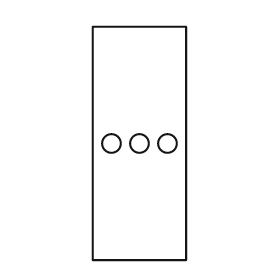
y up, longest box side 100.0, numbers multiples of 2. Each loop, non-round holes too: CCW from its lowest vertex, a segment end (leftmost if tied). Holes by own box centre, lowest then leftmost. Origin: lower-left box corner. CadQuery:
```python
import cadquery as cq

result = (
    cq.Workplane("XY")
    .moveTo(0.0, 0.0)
    .lineTo(40.0, 0.0)
    .lineTo(40.0, 100.0)
    .lineTo(0.0, 100.0)
    .close()
    .moveTo(8.0, 50.0)
    .circle(4.0)
    .moveTo(20.0, 50.0)
    .circle(4.0)
    .moveTo(32.0, 50.0)
    .circle(4.0)
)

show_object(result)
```